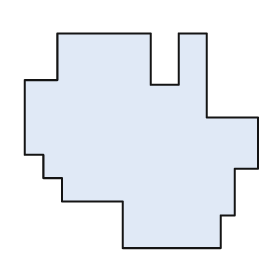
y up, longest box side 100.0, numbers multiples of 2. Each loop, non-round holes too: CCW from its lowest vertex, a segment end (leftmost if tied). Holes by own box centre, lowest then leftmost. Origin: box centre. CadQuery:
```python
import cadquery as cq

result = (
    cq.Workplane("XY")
    .moveTo(-8.0, -46.0)
    .lineTo(34.0, -46.0)
    .lineTo(34.0, -32.0)
    .lineTo(40.0, -32.0)
    .lineTo(40.0, -12.0)
    .lineTo(50.0, -12.0)
    .lineTo(50.0, 10.0)
    .lineTo(28.0, 10.0)
    .lineTo(28.0, 46.0)
    .lineTo(16.0, 46.0)
    .lineTo(16.0, 24.0)
    .lineTo(4.0, 24.0)
    .lineTo(4.0, 46.0)
    .lineTo(-36.0, 46.0)
    .lineTo(-36.0, 26.0)
    .lineTo(-50.0, 26.0)
    .lineTo(-50.0, -6.0)
    .lineTo(-42.0, -6.0)
    .lineTo(-42.0, -16.0)
    .lineTo(-34.0, -16.0)
    .lineTo(-34.0, -26.0)
    .lineTo(-8.0, -26.0)
    .close()
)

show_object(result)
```